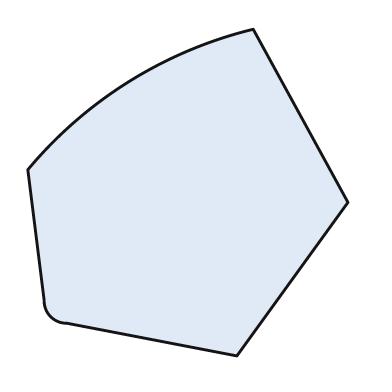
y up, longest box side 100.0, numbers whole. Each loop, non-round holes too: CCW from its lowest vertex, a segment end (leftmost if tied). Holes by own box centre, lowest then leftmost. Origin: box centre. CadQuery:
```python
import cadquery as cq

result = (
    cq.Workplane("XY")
    .moveTo(15.0, -50.0)
    .lineTo(49.0, -3.0)
    .lineTo(20.0, 50.0)
    .threePointArc((-18.0, 34.0), (-49.0, 7.0))
    .lineTo(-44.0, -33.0)
    .threePointArc((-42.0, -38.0), (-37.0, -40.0))
    .close()
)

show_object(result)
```